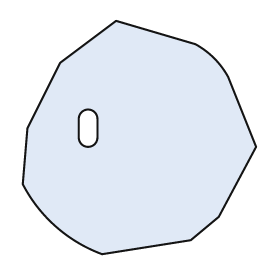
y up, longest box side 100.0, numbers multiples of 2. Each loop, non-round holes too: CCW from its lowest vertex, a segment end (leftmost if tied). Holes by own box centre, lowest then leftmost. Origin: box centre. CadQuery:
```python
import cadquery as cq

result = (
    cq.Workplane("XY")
    .moveTo(-16.0, -50.0)
    .lineTo(22.0, -44.0)
    .lineTo(34.0, -34.0)
    .lineTo(50.0, -4.0)
    .lineTo(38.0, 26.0)
    .threePointArc((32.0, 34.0), (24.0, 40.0))
    .lineTo(-10.0, 50.0)
    .lineTo(-34.0, 32.0)
    .lineTo(-48.0, 4.0)
    .lineTo(-50.0, -20.0)
    .threePointArc((-36.0, -38.0), (-16.0, -50.0))
    .close()
    .moveTo(-26.0, 0.0)
    .threePointArc((-22.0, -4.0), (-18.0, 0.0))
    .lineTo(-18.0, 8.0)
    .threePointArc((-22.0, 12.0), (-26.0, 8.0))
    .close()
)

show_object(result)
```